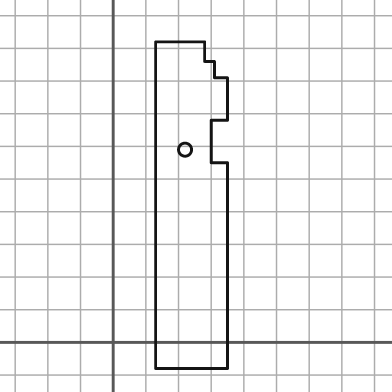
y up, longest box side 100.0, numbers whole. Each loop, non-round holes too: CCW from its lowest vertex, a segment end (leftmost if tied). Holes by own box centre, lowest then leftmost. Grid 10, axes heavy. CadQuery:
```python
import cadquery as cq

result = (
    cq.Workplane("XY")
    .moveTo(13.0, -8.0)
    .lineTo(35.0, -8.0)
    .lineTo(35.0, 55.0)
    .lineTo(30.0, 55.0)
    .lineTo(30.0, 68.0)
    .lineTo(35.0, 68.0)
    .lineTo(35.0, 81.0)
    .lineTo(31.0, 81.0)
    .lineTo(31.0, 86.0)
    .lineTo(28.0, 86.0)
    .lineTo(28.0, 92.0)
    .lineTo(13.0, 92.0)
    .close()
    .moveTo(22.0, 59.0)
    .circle(2.0)
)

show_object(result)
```